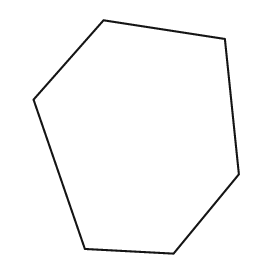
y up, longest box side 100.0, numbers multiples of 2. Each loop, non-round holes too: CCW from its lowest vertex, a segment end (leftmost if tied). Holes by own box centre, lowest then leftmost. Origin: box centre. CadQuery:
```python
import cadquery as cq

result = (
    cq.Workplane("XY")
    .moveTo(16.0, -50.0)
    .lineTo(44.0, -16.0)
    .lineTo(38.0, 42.0)
    .lineTo(-14.0, 50.0)
    .lineTo(-44.0, 16.0)
    .lineTo(-22.0, -48.0)
    .close()
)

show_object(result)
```